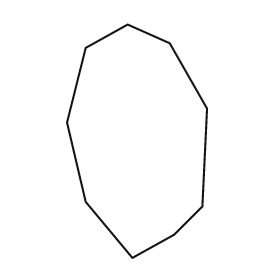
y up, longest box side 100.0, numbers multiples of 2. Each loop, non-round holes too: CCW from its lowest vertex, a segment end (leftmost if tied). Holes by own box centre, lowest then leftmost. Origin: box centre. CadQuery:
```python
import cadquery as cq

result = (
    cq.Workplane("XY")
    .moveTo(-2.0, -50.0)
    .lineTo(16.0, -40.0)
    .lineTo(28.0, -28.0)
    .lineTo(30.0, 14.0)
    .lineTo(14.0, 42.0)
    .lineTo(-4.0, 50.0)
    .lineTo(-22.0, 40.0)
    .lineTo(-30.0, 8.0)
    .lineTo(-22.0, -26.0)
    .close()
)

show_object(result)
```